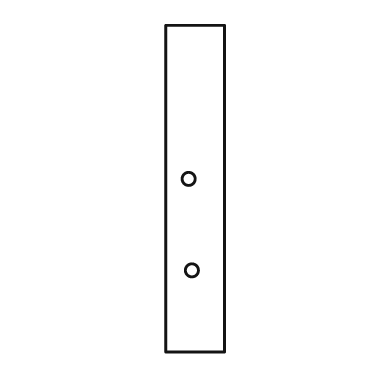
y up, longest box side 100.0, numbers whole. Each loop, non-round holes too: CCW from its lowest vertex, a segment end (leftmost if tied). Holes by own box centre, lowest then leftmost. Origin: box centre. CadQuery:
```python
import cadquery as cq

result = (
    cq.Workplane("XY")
    .moveTo(-9.0, -50.0)
    .lineTo(9.0, -50.0)
    .lineTo(9.0, 50.0)
    .lineTo(-9.0, 50.0)
    .close()
    .moveTo(-1.0, -25.0)
    .circle(2.0)
    .moveTo(-2.0, 3.0)
    .circle(2.0)
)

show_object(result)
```